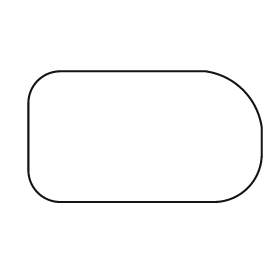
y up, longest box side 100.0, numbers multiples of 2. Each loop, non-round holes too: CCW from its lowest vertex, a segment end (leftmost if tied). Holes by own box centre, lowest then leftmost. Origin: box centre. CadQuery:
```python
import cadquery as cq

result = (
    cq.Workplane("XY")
    .moveTo(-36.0, -28.0)
    .lineTo(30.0, -28.0)
    .threePointArc((44.0, -22.0), (50.0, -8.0))
    .lineTo(50.0, 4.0)
    .threePointArc((42.0, 20.0), (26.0, 28.0))
    .lineTo(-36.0, 28.0)
    .threePointArc((-46.0, 24.0), (-50.0, 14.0))
    .lineTo(-50.0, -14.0)
    .threePointArc((-46.0, -24.0), (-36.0, -28.0))
    .close()
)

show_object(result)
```